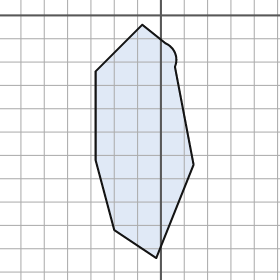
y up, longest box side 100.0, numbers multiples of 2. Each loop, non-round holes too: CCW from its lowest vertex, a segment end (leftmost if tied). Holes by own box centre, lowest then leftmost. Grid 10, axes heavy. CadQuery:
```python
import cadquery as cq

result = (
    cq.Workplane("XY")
    .moveTo(-2.0, -104.0)
    .lineTo(14.0, -64.0)
    .lineTo(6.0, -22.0)
    .threePointArc((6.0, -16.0), (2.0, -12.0))
    .lineTo(-8.0, -4.0)
    .lineTo(-28.0, -24.0)
    .lineTo(-28.0, -62.0)
    .lineTo(-20.0, -92.0)
    .close()
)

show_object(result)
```